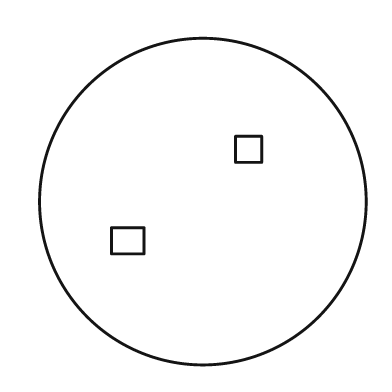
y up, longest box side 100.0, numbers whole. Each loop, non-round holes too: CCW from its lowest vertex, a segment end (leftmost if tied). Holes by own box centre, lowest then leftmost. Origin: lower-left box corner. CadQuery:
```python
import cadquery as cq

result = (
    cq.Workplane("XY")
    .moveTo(50.0, 50.0)
    .circle(50.0)
    .moveTo(22.0, 34.0)
    .lineTo(32.0, 34.0)
    .lineTo(32.0, 42.0)
    .lineTo(22.0, 42.0)
    .close()
    .moveTo(60.0, 62.0)
    .lineTo(68.0, 62.0)
    .lineTo(68.0, 70.0)
    .lineTo(60.0, 70.0)
    .close()
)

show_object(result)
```